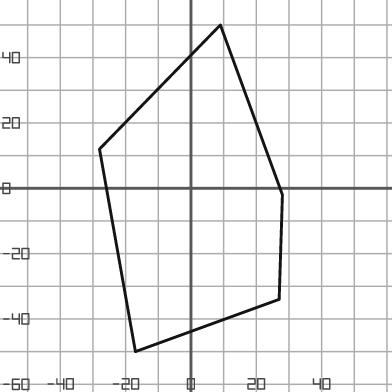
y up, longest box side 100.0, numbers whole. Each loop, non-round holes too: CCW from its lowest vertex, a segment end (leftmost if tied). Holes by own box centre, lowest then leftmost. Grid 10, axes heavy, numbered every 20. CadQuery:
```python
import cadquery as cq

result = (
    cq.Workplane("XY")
    .moveTo(-17.0, -50.0)
    .lineTo(27.0, -34.0)
    .lineTo(28.0, -2.0)
    .lineTo(9.0, 50.0)
    .lineTo(-28.0, 12.0)
    .close()
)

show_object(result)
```